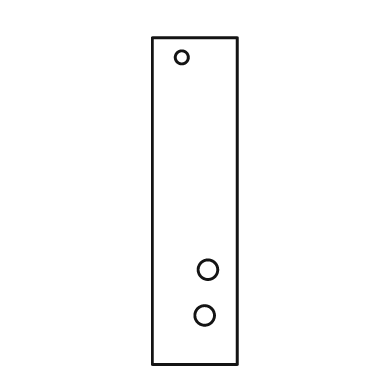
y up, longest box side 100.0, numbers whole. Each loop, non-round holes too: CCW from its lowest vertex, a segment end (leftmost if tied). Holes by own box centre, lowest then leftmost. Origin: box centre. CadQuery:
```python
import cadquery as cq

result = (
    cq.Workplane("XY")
    .moveTo(-13.0, -50.0)
    .lineTo(13.0, -50.0)
    .lineTo(13.0, 50.0)
    .lineTo(-13.0, 50.0)
    .close()
    .moveTo(3.0, -35.0)
    .circle(3.0)
    .moveTo(4.0, -21.0)
    .circle(3.0)
    .moveTo(-4.0, 44.0)
    .circle(2.0)
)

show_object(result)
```